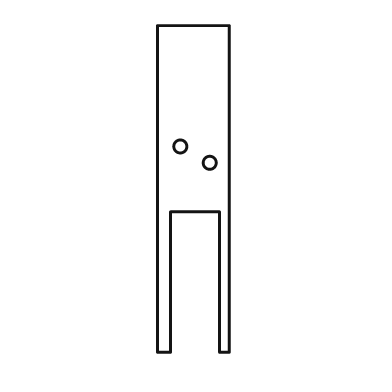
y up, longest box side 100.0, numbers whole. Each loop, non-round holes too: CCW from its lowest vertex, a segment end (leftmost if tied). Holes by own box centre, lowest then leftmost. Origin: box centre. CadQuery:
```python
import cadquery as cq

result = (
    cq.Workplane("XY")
    .moveTo(-11.0, -50.0)
    .lineTo(-7.0, -50.0)
    .lineTo(-7.0, -7.0)
    .lineTo(8.0, -7.0)
    .lineTo(8.0, -50.0)
    .lineTo(11.0, -50.0)
    .lineTo(11.0, 50.0)
    .lineTo(-11.0, 50.0)
    .close()
    .moveTo(5.0, 8.0)
    .circle(2.0)
    .moveTo(-4.0, 13.0)
    .circle(2.0)
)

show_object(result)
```